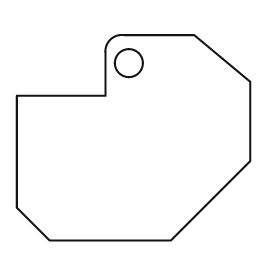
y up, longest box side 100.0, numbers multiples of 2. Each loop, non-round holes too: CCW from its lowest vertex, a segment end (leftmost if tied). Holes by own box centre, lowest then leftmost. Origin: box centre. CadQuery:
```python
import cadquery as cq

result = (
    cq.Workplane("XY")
    .moveTo(-36.0, -44.0)
    .lineTo(16.0, -44.0)
    .lineTo(50.0, -10.0)
    .lineTo(50.0, 24.0)
    .lineTo(26.0, 44.0)
    .lineTo(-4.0, 44.0)
    .threePointArc((-10.0, 42.0), (-12.0, 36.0))
    .lineTo(-12.0, 18.0)
    .lineTo(-50.0, 18.0)
    .lineTo(-50.0, -30.0)
    .close()
    .moveTo(-2.0, 32.0)
    .circle(6.0)
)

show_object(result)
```